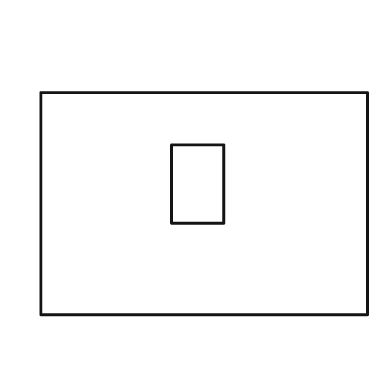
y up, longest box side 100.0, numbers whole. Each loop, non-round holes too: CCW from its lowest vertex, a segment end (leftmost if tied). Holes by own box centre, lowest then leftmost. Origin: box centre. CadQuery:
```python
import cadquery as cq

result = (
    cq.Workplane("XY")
    .moveTo(-50.0, -34.0)
    .lineTo(50.0, -34.0)
    .lineTo(50.0, 34.0)
    .lineTo(-50.0, 34.0)
    .close()
    .moveTo(-10.0, -6.0)
    .lineTo(6.0, -6.0)
    .lineTo(6.0, 18.0)
    .lineTo(-10.0, 18.0)
    .close()
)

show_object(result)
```